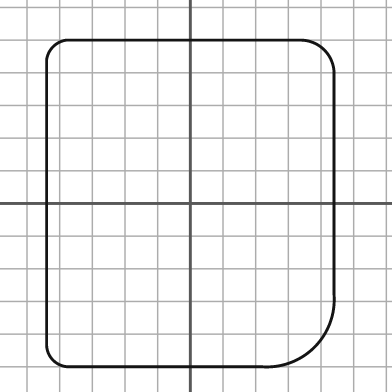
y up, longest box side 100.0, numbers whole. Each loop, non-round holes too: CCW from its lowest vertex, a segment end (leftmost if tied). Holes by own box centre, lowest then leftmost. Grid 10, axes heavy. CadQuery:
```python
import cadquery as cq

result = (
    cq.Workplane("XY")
    .moveTo(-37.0, -50.0)
    .lineTo(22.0, -50.0)
    .threePointArc((38.0, -44.0), (44.0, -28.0))
    .lineTo(44.0, 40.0)
    .threePointArc((41.0, 47.0), (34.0, 50.0))
    .lineTo(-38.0, 50.0)
    .threePointArc((-42.0, 48.0), (-44.0, 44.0))
    .lineTo(-44.0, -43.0)
    .threePointArc((-42.0, -48.0), (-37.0, -50.0))
    .close()
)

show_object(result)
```